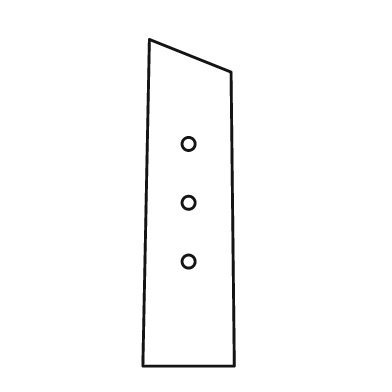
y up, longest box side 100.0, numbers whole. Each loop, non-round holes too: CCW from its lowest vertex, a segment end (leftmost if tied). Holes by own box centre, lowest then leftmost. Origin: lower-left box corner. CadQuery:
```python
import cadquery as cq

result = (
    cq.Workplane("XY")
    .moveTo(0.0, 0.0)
    .lineTo(28.0, 0.0)
    .lineTo(27.0, 90.0)
    .lineTo(2.0, 100.0)
    .close()
    .moveTo(14.0, 32.0)
    .circle(2.0)
    .moveTo(14.0, 50.0)
    .circle(2.0)
    .moveTo(14.0, 68.0)
    .circle(2.0)
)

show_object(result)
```